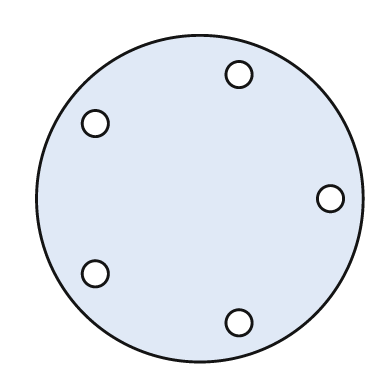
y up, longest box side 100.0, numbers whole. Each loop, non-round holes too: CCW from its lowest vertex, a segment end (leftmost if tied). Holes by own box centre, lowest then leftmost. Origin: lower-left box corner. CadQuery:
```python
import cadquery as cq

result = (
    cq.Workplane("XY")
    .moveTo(50.0, 50.0)
    .circle(50.0)
    .moveTo(62.0, 12.0)
    .circle(4.0)
    .moveTo(18.0, 27.0)
    .circle(4.0)
    .moveTo(90.0, 50.0)
    .circle(4.0)
    .moveTo(18.0, 73.0)
    .circle(4.0)
    .moveTo(62.0, 88.0)
    .circle(4.0)
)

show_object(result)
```